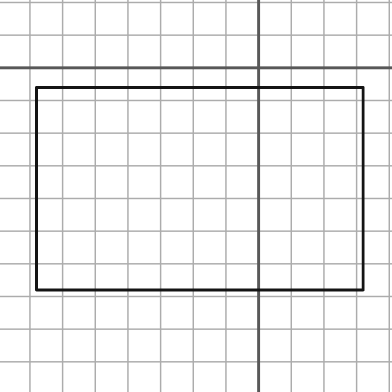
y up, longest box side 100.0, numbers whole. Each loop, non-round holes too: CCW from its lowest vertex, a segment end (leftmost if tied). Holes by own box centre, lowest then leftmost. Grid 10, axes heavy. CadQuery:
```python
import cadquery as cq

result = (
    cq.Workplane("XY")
    .moveTo(-68.0, -68.0)
    .lineTo(32.0, -68.0)
    .lineTo(32.0, -6.0)
    .lineTo(-68.0, -6.0)
    .close()
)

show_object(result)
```